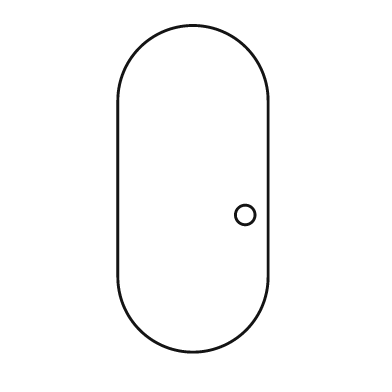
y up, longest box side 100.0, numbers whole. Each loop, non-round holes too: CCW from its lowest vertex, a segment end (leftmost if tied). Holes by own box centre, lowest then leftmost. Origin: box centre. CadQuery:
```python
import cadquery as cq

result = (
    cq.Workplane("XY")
    .moveTo(-23.0, -27.0)
    .threePointArc((0.0, -50.0), (23.0, -27.0))
    .lineTo(23.0, 27.0)
    .threePointArc((0.0, 50.0), (-23.0, 27.0))
    .close()
    .moveTo(16.0, -8.0)
    .circle(3.0)
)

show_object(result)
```